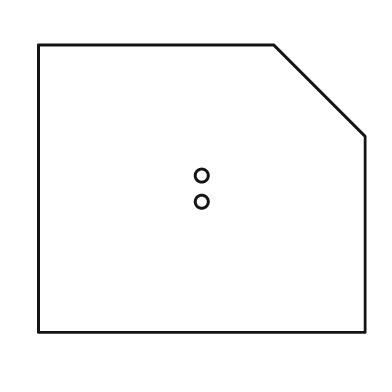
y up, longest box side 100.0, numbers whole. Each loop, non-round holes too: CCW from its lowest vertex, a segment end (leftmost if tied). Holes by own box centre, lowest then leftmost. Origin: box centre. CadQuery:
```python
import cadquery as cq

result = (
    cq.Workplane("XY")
    .moveTo(-50.0, -44.0)
    .lineTo(50.0, -44.0)
    .lineTo(50.0, 16.0)
    .lineTo(22.0, 44.0)
    .lineTo(-50.0, 44.0)
    .close()
    .moveTo(0.0, -4.0)
    .circle(2.0)
    .moveTo(0.0, 4.0)
    .circle(2.0)
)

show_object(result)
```